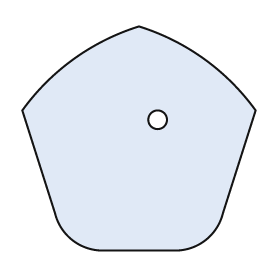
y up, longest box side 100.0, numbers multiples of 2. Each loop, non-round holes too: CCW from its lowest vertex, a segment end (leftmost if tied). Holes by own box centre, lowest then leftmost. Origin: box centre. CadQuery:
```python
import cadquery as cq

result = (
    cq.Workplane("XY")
    .moveTo(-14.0, -48.0)
    .lineTo(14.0, -48.0)
    .threePointArc((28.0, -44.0), (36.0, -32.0))
    .lineTo(50.0, 12.0)
    .threePointArc((28.0, 34.0), (0.0, 48.0))
    .threePointArc((-28.0, 34.0), (-50.0, 12.0))
    .lineTo(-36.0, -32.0)
    .threePointArc((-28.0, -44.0), (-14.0, -48.0))
    .close()
    .moveTo(8.0, 8.0)
    .circle(4.0)
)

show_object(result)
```